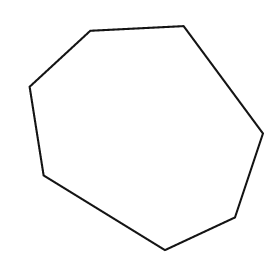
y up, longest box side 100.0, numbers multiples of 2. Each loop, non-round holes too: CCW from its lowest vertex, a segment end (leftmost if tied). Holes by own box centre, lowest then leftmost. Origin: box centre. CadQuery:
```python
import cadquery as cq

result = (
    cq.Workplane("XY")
    .moveTo(8.0, -48.0)
    .lineTo(38.0, -34.0)
    .lineTo(50.0, 2.0)
    .lineTo(16.0, 48.0)
    .lineTo(-24.0, 46.0)
    .lineTo(-50.0, 22.0)
    .lineTo(-44.0, -16.0)
    .close()
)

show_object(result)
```